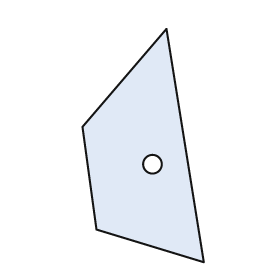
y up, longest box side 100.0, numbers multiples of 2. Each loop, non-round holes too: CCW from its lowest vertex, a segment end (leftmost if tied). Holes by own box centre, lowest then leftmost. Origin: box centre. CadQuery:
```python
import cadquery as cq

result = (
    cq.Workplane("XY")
    .moveTo(26.0, -50.0)
    .lineTo(10.0, 50.0)
    .lineTo(-26.0, 8.0)
    .lineTo(-20.0, -36.0)
    .close()
    .moveTo(4.0, -8.0)
    .circle(4.0)
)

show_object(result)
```